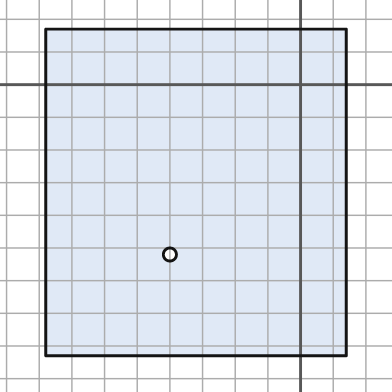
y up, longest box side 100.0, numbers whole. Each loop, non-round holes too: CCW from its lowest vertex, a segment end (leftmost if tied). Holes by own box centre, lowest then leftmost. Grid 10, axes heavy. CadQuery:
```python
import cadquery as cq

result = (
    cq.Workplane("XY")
    .moveTo(-78.0, -83.0)
    .lineTo(14.0, -83.0)
    .lineTo(14.0, 17.0)
    .lineTo(-78.0, 17.0)
    .close()
    .moveTo(-40.0, -52.0)
    .circle(2.0)
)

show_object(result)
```